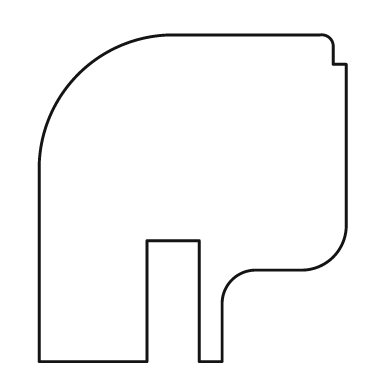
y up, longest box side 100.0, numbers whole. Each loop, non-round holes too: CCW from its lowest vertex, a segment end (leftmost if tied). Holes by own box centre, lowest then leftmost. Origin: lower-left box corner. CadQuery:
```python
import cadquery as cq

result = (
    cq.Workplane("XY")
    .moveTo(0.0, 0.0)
    .lineTo(33.0, 0.0)
    .lineTo(33.0, 37.0)
    .lineTo(49.0, 37.0)
    .lineTo(49.0, 0.0)
    .lineTo(56.0, 0.0)
    .lineTo(56.0, 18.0)
    .threePointArc((59.0, 25.0), (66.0, 28.0))
    .lineTo(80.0, 28.0)
    .threePointArc((90.0, 32.0), (94.0, 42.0))
    .lineTo(94.0, 91.0)
    .lineTo(90.0, 91.0)
    .lineTo(90.0, 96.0)
    .threePointArc((89.0, 99.0), (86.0, 100.0))
    .lineTo(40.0, 100.0)
    .threePointArc((12.0, 88.0), (0.0, 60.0))
    .close()
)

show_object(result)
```